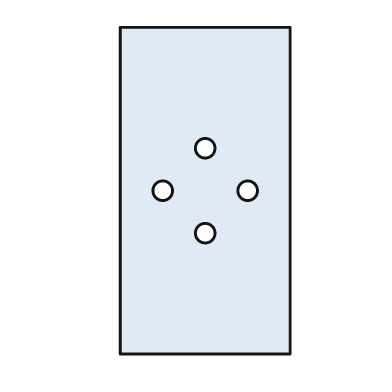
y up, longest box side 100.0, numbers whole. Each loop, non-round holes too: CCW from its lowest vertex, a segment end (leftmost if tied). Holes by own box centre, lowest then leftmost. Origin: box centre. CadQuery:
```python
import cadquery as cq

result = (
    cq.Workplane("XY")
    .moveTo(-26.0, -50.0)
    .lineTo(26.0, -50.0)
    .lineTo(26.0, 50.0)
    .lineTo(-26.0, 50.0)
    .close()
    .moveTo(0.0, -13.0)
    .circle(3.0)
    .moveTo(-13.0, 0.0)
    .circle(3.0)
    .moveTo(13.0, 0.0)
    .circle(3.0)
    .moveTo(0.0, 13.0)
    .circle(3.0)
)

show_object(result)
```